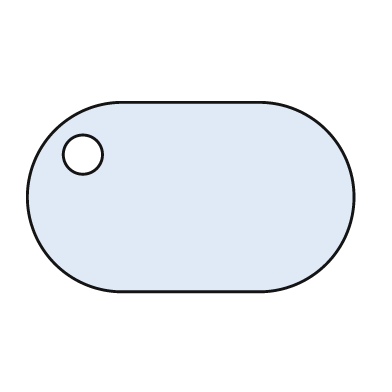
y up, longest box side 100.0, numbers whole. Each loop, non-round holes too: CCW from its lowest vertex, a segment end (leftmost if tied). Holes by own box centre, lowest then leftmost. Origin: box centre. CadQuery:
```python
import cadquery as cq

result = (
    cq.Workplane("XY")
    .moveTo(-21.0, -29.0)
    .lineTo(21.0, -29.0)
    .threePointArc((50.0, 0.0), (21.0, 29.0))
    .lineTo(-21.0, 29.0)
    .threePointArc((-50.0, 0.0), (-21.0, -29.0))
    .close()
    .moveTo(-33.0, 13.0)
    .circle(6.0)
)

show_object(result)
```